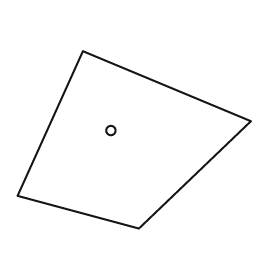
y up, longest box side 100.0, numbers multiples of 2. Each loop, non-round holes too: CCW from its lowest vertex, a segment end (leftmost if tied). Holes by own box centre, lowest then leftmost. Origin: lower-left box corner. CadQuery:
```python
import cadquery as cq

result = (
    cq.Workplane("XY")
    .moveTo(52.0, 0.0)
    .lineTo(100.0, 46.0)
    .lineTo(28.0, 76.0)
    .lineTo(0.0, 14.0)
    .close()
    .moveTo(40.0, 42.0)
    .circle(2.0)
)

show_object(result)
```